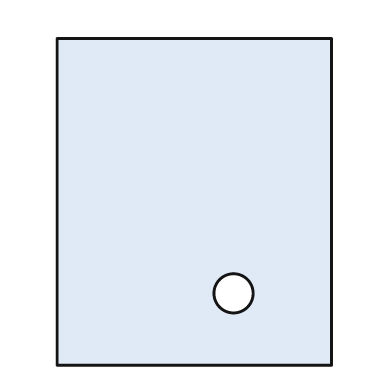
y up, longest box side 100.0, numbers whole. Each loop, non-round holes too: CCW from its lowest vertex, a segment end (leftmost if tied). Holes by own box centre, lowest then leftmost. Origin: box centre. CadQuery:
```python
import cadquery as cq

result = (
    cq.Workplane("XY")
    .moveTo(-42.0, -50.0)
    .lineTo(42.0, -50.0)
    .lineTo(42.0, 50.0)
    .lineTo(-42.0, 50.0)
    .close()
    .moveTo(12.0, -28.0)
    .circle(6.0)
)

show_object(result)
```